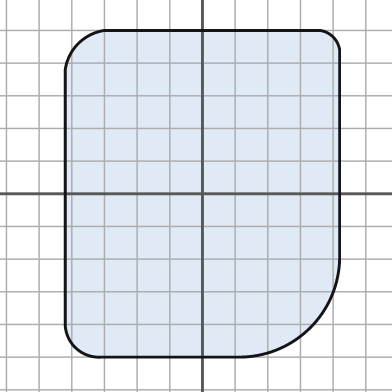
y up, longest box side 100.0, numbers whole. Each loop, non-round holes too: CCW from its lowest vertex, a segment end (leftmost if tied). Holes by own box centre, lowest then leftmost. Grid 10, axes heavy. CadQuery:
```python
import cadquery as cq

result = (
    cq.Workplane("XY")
    .moveTo(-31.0, -50.0)
    .lineTo(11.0, -50.0)
    .threePointArc((33.0, -41.0), (42.0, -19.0))
    .lineTo(42.0, 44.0)
    .threePointArc((40.0, 48.0), (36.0, 50.0))
    .lineTo(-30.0, 50.0)
    .threePointArc((-38.0, 46.0), (-42.0, 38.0))
    .lineTo(-42.0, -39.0)
    .threePointArc((-39.0, -47.0), (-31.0, -50.0))
    .close()
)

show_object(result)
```